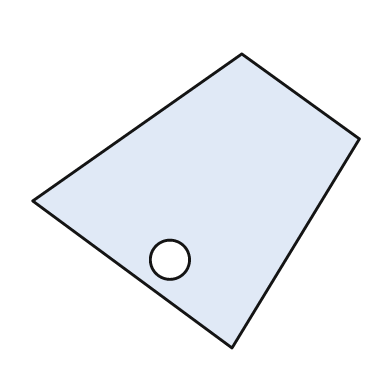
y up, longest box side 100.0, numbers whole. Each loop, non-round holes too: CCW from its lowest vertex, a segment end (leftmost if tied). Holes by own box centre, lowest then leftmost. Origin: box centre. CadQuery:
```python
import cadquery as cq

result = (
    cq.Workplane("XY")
    .moveTo(11.0, -45.0)
    .lineTo(50.0, 19.0)
    .lineTo(14.0, 45.0)
    .lineTo(-50.0, 0.0)
    .close()
    .moveTo(-8.0, -18.0)
    .circle(6.0)
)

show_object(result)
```